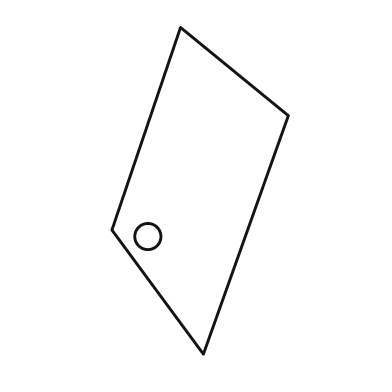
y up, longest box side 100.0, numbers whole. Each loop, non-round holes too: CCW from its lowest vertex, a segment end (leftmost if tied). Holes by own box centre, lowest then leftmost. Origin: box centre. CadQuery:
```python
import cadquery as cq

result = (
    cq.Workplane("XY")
    .moveTo(1.0, -50.0)
    .lineTo(27.0, 23.0)
    .lineTo(-6.0, 50.0)
    .lineTo(-27.0, -12.0)
    .close()
    .moveTo(-16.0, -14.0)
    .circle(4.0)
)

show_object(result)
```